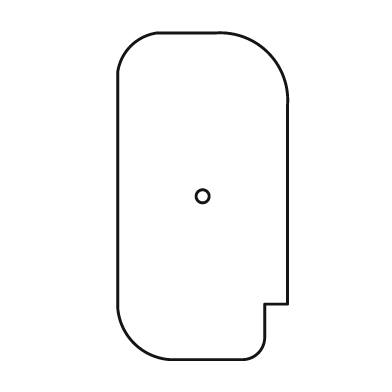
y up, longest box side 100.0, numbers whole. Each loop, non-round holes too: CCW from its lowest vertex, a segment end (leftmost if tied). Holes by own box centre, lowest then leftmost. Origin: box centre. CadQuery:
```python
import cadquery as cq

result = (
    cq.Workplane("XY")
    .moveTo(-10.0, -50.0)
    .lineTo(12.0, -50.0)
    .threePointArc((17.0, -48.0), (19.0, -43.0))
    .lineTo(19.0, -33.0)
    .lineTo(26.0, -33.0)
    .lineTo(26.0, 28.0)
    .threePointArc((20.0, 44.0), (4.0, 50.0))
    .lineTo(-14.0, 50.0)
    .threePointArc((-22.0, 46.0), (-26.0, 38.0))
    .lineTo(-26.0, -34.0)
    .threePointArc((-21.0, -45.0), (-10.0, -50.0))
    .close()
    .moveTo(0.0, 0.0)
    .circle(2.0)
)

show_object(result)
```